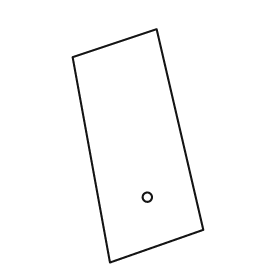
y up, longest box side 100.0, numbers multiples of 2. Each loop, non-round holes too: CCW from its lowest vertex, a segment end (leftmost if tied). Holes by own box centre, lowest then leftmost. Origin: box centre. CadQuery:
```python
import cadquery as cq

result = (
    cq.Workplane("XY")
    .moveTo(-12.0, -50.0)
    .lineTo(28.0, -36.0)
    .lineTo(8.0, 50.0)
    .lineTo(-28.0, 38.0)
    .close()
    .moveTo(4.0, -22.0)
    .circle(2.0)
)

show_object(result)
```